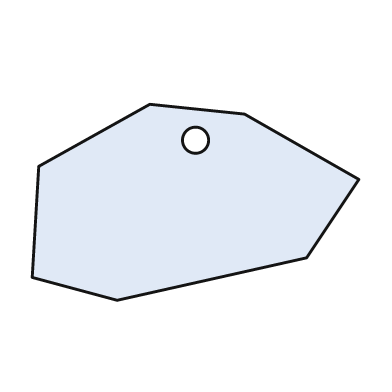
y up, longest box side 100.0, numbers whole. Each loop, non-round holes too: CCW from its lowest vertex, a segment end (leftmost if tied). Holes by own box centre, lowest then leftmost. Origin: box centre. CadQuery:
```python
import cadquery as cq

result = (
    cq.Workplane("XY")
    .moveTo(-24.0, -30.0)
    .lineTo(34.0, -17.0)
    .lineTo(50.0, 7.0)
    .lineTo(15.0, 27.0)
    .lineTo(-14.0, 30.0)
    .lineTo(-48.0, 11.0)
    .lineTo(-50.0, -23.0)
    .close()
    .moveTo(0.0, 19.0)
    .circle(4.0)
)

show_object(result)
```